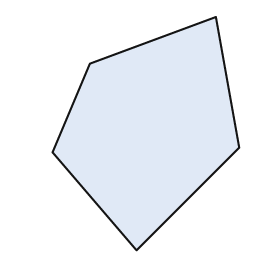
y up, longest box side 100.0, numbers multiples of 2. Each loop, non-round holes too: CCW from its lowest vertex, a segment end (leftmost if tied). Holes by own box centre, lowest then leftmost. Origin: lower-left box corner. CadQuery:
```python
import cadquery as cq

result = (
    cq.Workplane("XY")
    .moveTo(36.0, 0.0)
    .lineTo(80.0, 44.0)
    .lineTo(70.0, 100.0)
    .lineTo(16.0, 80.0)
    .lineTo(0.0, 42.0)
    .close()
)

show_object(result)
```